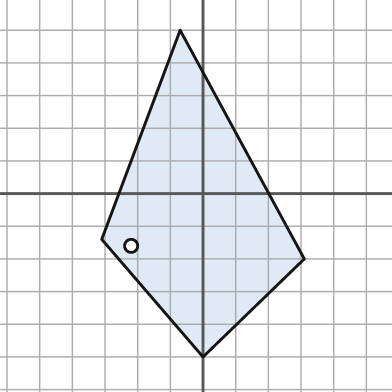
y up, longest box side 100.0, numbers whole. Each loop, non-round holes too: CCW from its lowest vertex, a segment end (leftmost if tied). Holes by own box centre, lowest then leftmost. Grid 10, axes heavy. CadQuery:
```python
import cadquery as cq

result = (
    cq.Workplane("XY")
    .moveTo(0.0, -50.0)
    .lineTo(31.0, -20.0)
    .lineTo(-7.0, 50.0)
    .lineTo(-31.0, -14.0)
    .close()
    .moveTo(-22.0, -16.0)
    .circle(2.0)
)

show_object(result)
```